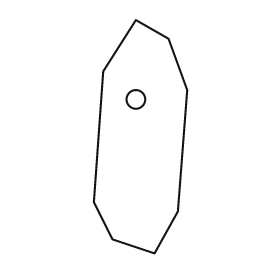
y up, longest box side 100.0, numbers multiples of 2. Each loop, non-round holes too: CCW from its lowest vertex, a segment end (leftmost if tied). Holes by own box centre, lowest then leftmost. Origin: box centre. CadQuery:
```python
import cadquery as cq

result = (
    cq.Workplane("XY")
    .moveTo(6.0, -50.0)
    .lineTo(16.0, -32.0)
    .lineTo(20.0, 20.0)
    .lineTo(12.0, 42.0)
    .lineTo(-2.0, 50.0)
    .lineTo(-16.0, 28.0)
    .lineTo(-20.0, -28.0)
    .lineTo(-12.0, -44.0)
    .close()
    .moveTo(-2.0, 16.0)
    .circle(4.0)
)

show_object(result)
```